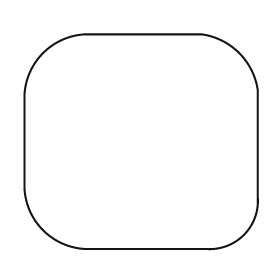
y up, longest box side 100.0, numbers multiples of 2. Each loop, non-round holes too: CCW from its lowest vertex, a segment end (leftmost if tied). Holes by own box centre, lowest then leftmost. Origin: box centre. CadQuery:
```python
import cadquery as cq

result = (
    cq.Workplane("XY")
    .moveTo(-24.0, -46.0)
    .lineTo(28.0, -46.0)
    .threePointArc((44.0, -40.0), (50.0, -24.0))
    .lineTo(50.0, 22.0)
    .threePointArc((42.0, 38.0), (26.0, 46.0))
    .lineTo(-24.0, 46.0)
    .threePointArc((-42.0, 38.0), (-50.0, 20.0))
    .lineTo(-50.0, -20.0)
    .threePointArc((-42.0, -38.0), (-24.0, -46.0))
    .close()
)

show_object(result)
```